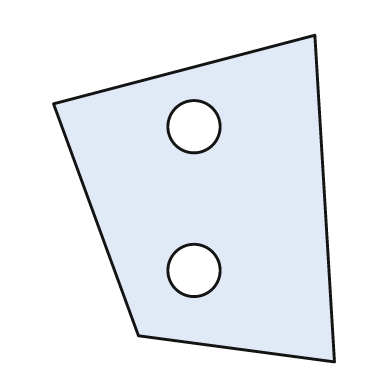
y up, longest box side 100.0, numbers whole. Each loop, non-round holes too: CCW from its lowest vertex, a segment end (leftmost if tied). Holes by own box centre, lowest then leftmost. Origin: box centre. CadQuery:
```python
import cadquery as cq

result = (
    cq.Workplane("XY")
    .moveTo(43.0, -50.0)
    .lineTo(37.0, 50.0)
    .lineTo(-43.0, 29.0)
    .lineTo(-17.0, -42.0)
    .close()
    .moveTo(0.0, -22.0)
    .circle(8.0)
    .moveTo(0.0, 22.0)
    .circle(8.0)
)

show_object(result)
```